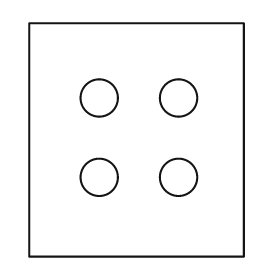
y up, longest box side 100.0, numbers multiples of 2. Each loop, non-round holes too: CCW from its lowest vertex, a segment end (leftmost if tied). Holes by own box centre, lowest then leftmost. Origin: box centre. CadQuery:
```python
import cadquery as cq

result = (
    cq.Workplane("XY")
    .moveTo(-46.0, -50.0)
    .lineTo(46.0, -50.0)
    .lineTo(46.0, 50.0)
    .lineTo(-46.0, 50.0)
    .close()
    .moveTo(-16.0, -16.0)
    .circle(8.0)
    .moveTo(18.0, -16.0)
    .circle(8.0)
    .moveTo(-16.0, 18.0)
    .circle(8.0)
    .moveTo(18.0, 18.0)
    .circle(8.0)
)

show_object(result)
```